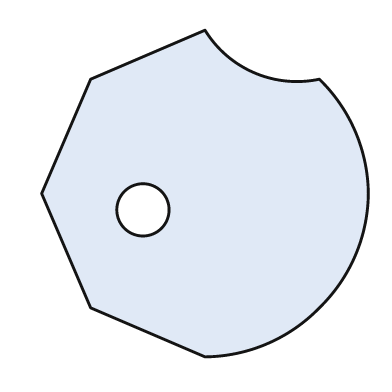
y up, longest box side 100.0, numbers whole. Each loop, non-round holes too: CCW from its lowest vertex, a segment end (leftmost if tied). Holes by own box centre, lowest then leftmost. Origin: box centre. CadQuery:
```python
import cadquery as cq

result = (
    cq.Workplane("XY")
    .moveTo(0.0, -50.0)
    .threePointArc((19.0, -46.0), (35.0, -35.0))
    .threePointArc((46.0, -19.0), (50.0, 0.0))
    .threePointArc((46.0, 19.0), (35.0, 35.0))
    .threePointArc((15.0, 37.0), (0.0, 50.0))
    .lineTo(-35.0, 35.0)
    .lineTo(-50.0, 0.0)
    .lineTo(-35.0, -35.0)
    .close()
    .moveTo(-19.0, -5.0)
    .circle(8.0)
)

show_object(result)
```